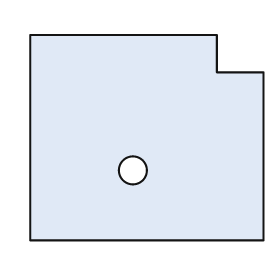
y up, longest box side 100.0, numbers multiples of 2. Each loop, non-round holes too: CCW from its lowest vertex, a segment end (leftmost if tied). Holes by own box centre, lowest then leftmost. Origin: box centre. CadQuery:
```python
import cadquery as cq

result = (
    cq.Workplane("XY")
    .moveTo(-50.0, -44.0)
    .lineTo(50.0, -44.0)
    .lineTo(50.0, 28.0)
    .lineTo(30.0, 28.0)
    .lineTo(30.0, 44.0)
    .lineTo(-50.0, 44.0)
    .close()
    .moveTo(-6.0, -14.0)
    .circle(6.0)
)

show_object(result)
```